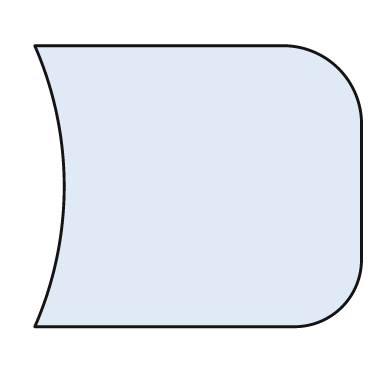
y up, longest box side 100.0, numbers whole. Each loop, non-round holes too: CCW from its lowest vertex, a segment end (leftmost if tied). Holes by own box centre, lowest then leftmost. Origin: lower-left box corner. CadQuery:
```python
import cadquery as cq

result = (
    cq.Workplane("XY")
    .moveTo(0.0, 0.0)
    .lineTo(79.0, 0.0)
    .threePointArc((94.0, 6.0), (100.0, 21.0))
    .lineTo(100.0, 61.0)
    .threePointArc((93.0, 79.0), (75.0, 86.0))
    .lineTo(0.0, 86.0)
    .threePointArc((9.0, 43.0), (0.0, 0.0))
    .close()
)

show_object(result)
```